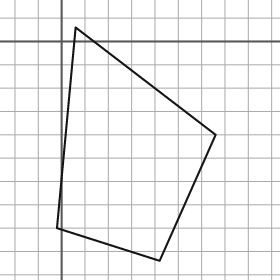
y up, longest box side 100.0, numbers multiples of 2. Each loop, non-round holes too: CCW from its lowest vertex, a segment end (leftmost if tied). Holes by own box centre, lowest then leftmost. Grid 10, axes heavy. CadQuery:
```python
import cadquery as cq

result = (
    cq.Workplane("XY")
    .moveTo(42.0, -94.0)
    .lineTo(66.0, -40.0)
    .lineTo(6.0, 6.0)
    .lineTo(-2.0, -80.0)
    .close()
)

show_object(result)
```